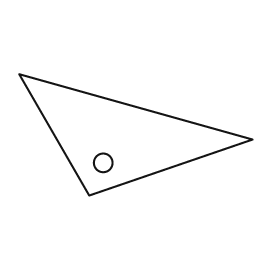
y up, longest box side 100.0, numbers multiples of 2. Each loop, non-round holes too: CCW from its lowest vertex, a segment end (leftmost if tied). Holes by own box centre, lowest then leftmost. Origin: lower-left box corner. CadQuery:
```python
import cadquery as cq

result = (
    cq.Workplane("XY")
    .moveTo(30.0, 0.0)
    .lineTo(100.0, 24.0)
    .lineTo(0.0, 52.0)
    .close()
    .moveTo(36.0, 14.0)
    .circle(4.0)
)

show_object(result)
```